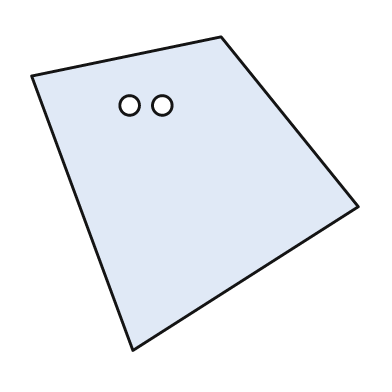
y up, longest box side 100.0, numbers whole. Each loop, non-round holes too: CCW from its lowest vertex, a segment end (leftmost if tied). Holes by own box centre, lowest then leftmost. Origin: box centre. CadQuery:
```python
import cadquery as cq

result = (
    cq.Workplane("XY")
    .moveTo(-19.0, -48.0)
    .lineTo(50.0, -4.0)
    .lineTo(8.0, 48.0)
    .lineTo(-50.0, 36.0)
    .close()
    .moveTo(-20.0, 27.0)
    .circle(3.0)
    .moveTo(-10.0, 27.0)
    .circle(3.0)
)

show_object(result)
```